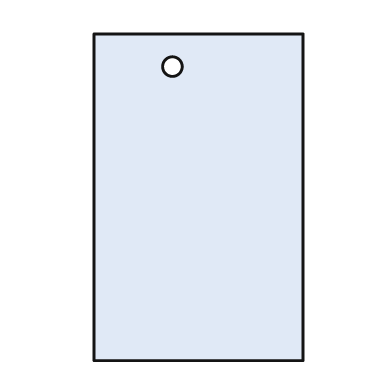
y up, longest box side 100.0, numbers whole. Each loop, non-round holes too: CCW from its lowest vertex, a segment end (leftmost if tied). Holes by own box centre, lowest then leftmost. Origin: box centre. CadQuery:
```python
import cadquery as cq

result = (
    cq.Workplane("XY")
    .moveTo(-32.0, -50.0)
    .lineTo(32.0, -50.0)
    .lineTo(32.0, 50.0)
    .lineTo(-32.0, 50.0)
    .close()
    .moveTo(-8.0, 40.0)
    .circle(3.0)
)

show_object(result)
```